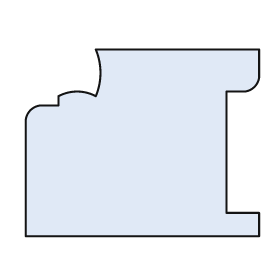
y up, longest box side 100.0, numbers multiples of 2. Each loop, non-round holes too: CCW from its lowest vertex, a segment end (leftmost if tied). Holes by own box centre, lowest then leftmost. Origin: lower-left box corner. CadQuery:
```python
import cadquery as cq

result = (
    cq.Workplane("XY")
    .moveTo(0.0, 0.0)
    .lineTo(100.0, 0.0)
    .lineTo(100.0, 10.0)
    .lineTo(86.0, 10.0)
    .lineTo(86.0, 62.0)
    .lineTo(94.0, 62.0)
    .threePointArc((98.0, 64.0), (100.0, 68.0))
    .lineTo(100.0, 80.0)
    .lineTo(30.0, 80.0)
    .threePointArc((32.0, 70.0), (30.0, 60.0))
    .threePointArc((22.0, 62.0), (14.0, 60.0))
    .lineTo(14.0, 56.0)
    .lineTo(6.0, 56.0)
    .threePointArc((2.0, 54.0), (0.0, 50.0))
    .close()
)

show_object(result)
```